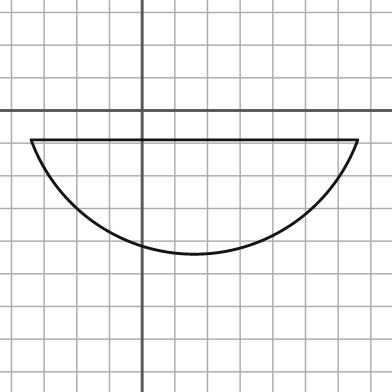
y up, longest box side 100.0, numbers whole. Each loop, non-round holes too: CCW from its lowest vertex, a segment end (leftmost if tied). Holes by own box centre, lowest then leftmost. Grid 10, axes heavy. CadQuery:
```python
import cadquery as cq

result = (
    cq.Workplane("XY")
    .moveTo(-34.0, -9.0)
    .threePointArc((16.0, -44.0), (66.0, -9.0))
    .close()
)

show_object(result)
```